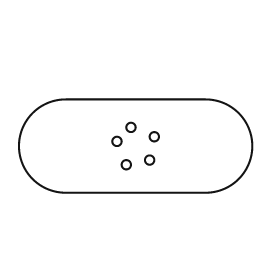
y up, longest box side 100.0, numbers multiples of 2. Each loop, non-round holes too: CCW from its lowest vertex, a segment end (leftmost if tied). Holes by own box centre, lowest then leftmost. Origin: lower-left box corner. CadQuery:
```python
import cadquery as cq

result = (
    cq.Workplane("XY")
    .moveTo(20.0, 0.0)
    .lineTo(80.0, 0.0)
    .threePointArc((100.0, 20.0), (80.0, 40.0))
    .lineTo(20.0, 40.0)
    .threePointArc((0.0, 20.0), (20.0, 0.0))
    .close()
    .moveTo(46.0, 12.0)
    .circle(2.0)
    .moveTo(56.0, 14.0)
    .circle(2.0)
    .moveTo(42.0, 22.0)
    .circle(2.0)
    .moveTo(58.0, 24.0)
    .circle(2.0)
    .moveTo(48.0, 28.0)
    .circle(2.0)
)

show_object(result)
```